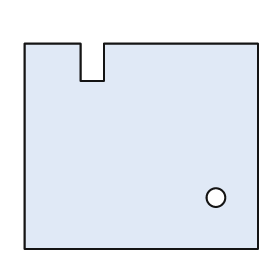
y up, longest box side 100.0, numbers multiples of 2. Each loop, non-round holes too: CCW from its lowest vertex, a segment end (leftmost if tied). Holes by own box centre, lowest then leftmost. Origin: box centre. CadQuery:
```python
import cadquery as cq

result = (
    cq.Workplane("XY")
    .moveTo(-50.0, -44.0)
    .lineTo(50.0, -44.0)
    .lineTo(50.0, 44.0)
    .lineTo(-16.0, 44.0)
    .lineTo(-16.0, 28.0)
    .lineTo(-26.0, 28.0)
    .lineTo(-26.0, 44.0)
    .lineTo(-50.0, 44.0)
    .close()
    .moveTo(32.0, -22.0)
    .circle(4.0)
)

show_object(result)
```